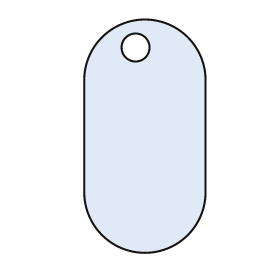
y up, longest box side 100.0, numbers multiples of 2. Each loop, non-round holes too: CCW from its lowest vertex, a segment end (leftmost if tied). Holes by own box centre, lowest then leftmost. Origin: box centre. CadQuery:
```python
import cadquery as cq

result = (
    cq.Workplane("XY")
    .moveTo(-26.0, -24.0)
    .threePointArc((0.0, -50.0), (26.0, -24.0))
    .lineTo(26.0, 24.0)
    .threePointArc((0.0, 50.0), (-26.0, 24.0))
    .close()
    .moveTo(-4.0, 38.0)
    .circle(6.0)
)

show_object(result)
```